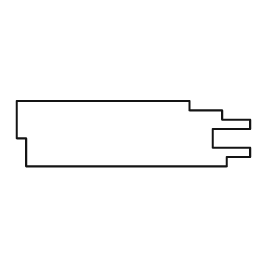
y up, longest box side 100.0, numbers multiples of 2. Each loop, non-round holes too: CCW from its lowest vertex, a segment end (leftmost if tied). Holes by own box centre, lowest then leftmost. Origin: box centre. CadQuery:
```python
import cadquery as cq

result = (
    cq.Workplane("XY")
    .moveTo(-46.0, -14.0)
    .lineTo(40.0, -14.0)
    .lineTo(40.0, -10.0)
    .lineTo(50.0, -10.0)
    .lineTo(50.0, -6.0)
    .lineTo(34.0, -6.0)
    .lineTo(34.0, 2.0)
    .lineTo(50.0, 2.0)
    .lineTo(50.0, 6.0)
    .lineTo(38.0, 6.0)
    .lineTo(38.0, 10.0)
    .lineTo(24.0, 10.0)
    .lineTo(24.0, 14.0)
    .lineTo(-50.0, 14.0)
    .lineTo(-50.0, -2.0)
    .lineTo(-46.0, -2.0)
    .close()
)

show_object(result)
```